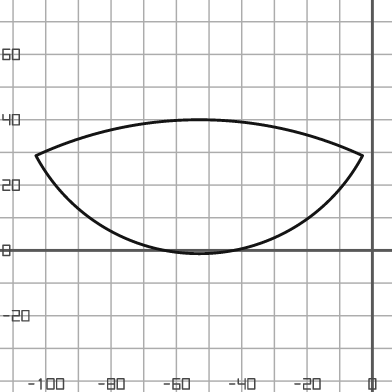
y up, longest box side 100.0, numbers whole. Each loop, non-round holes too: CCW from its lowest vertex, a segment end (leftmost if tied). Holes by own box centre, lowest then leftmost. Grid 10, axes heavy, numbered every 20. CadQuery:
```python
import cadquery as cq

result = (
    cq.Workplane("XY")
    .moveTo(-103.0, 29.0)
    .threePointArc((-53.0, -1.0), (-3.0, 29.0))
    .threePointArc((-53.0, 40.0), (-103.0, 29.0))
    .close()
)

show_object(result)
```